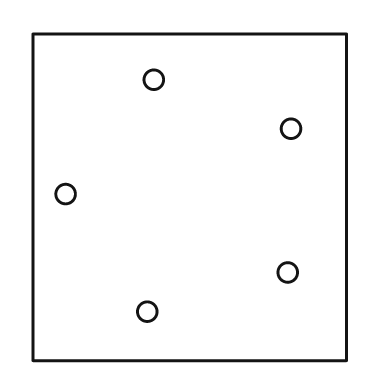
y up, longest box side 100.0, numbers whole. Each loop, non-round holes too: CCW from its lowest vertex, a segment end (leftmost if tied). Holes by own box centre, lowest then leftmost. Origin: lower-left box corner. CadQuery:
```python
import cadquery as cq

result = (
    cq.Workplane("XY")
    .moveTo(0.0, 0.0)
    .lineTo(96.0, 0.0)
    .lineTo(96.0, 100.0)
    .lineTo(0.0, 100.0)
    .close()
    .moveTo(35.0, 15.0)
    .circle(3.0)
    .moveTo(78.0, 27.0)
    .circle(3.0)
    .moveTo(10.0, 51.0)
    .circle(3.0)
    .moveTo(79.0, 71.0)
    .circle(3.0)
    .moveTo(37.0, 86.0)
    .circle(3.0)
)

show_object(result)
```